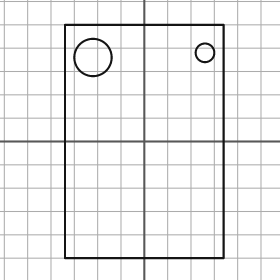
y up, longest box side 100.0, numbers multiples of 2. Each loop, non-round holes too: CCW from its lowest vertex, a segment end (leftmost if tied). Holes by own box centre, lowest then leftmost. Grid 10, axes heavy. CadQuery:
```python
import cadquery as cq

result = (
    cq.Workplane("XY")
    .moveTo(-34.0, -50.0)
    .lineTo(34.0, -50.0)
    .lineTo(34.0, 50.0)
    .lineTo(-34.0, 50.0)
    .close()
    .moveTo(-22.0, 36.0)
    .circle(8.0)
    .moveTo(26.0, 38.0)
    .circle(4.0)
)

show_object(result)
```